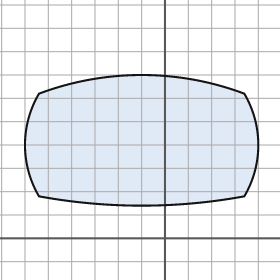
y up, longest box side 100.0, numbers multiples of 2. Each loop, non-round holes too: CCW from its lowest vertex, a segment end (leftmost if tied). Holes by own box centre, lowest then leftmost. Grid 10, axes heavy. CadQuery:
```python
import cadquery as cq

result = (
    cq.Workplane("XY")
    .moveTo(-54.0, 18.0)
    .threePointArc((-10.0, 14.0), (34.0, 18.0))
    .threePointArc((40.0, 40.0), (34.0, 62.0))
    .threePointArc((-10.0, 70.0), (-54.0, 62.0))
    .threePointArc((-60.0, 40.0), (-54.0, 18.0))
    .close()
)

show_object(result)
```